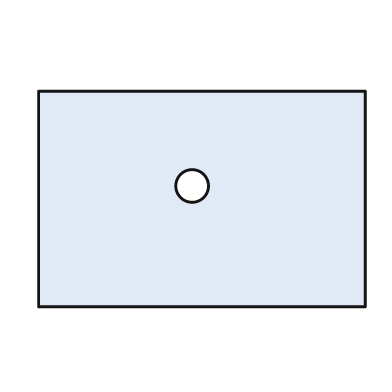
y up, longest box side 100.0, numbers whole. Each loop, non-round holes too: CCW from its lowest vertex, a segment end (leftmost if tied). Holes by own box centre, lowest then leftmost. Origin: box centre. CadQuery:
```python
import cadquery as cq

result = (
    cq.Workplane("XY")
    .moveTo(-50.0, -33.0)
    .lineTo(50.0, -33.0)
    .lineTo(50.0, 33.0)
    .lineTo(-50.0, 33.0)
    .close()
    .moveTo(-3.0, 4.0)
    .circle(5.0)
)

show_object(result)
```